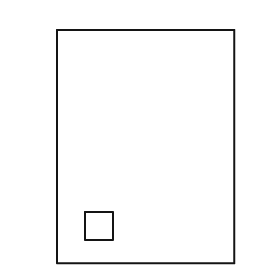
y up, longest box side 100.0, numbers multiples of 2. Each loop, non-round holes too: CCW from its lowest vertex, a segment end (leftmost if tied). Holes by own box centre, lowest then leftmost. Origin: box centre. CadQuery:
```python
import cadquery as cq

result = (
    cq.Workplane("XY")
    .moveTo(-38.0, -50.0)
    .lineTo(38.0, -50.0)
    .lineTo(38.0, 50.0)
    .lineTo(-38.0, 50.0)
    .close()
    .moveTo(-26.0, -40.0)
    .lineTo(-14.0, -40.0)
    .lineTo(-14.0, -28.0)
    .lineTo(-26.0, -28.0)
    .close()
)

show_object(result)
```